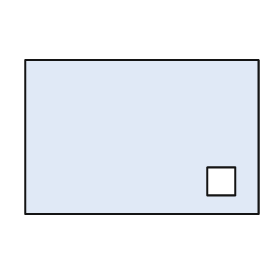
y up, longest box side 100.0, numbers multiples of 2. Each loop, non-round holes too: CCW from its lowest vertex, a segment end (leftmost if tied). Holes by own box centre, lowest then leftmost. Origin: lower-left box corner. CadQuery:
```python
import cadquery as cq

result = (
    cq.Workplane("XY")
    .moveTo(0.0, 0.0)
    .lineTo(100.0, 0.0)
    .lineTo(100.0, 66.0)
    .lineTo(0.0, 66.0)
    .close()
    .moveTo(78.0, 8.0)
    .lineTo(90.0, 8.0)
    .lineTo(90.0, 20.0)
    .lineTo(78.0, 20.0)
    .close()
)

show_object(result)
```